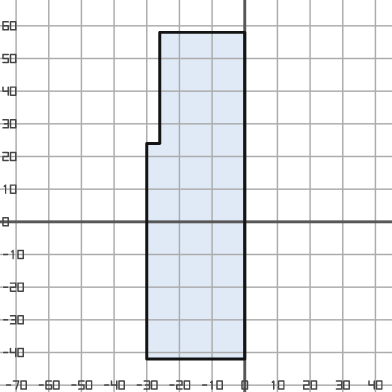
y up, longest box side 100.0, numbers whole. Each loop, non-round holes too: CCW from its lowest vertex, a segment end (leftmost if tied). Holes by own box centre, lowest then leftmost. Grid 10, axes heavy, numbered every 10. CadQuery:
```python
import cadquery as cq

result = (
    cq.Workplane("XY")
    .moveTo(-30.0, -42.0)
    .lineTo(0.0, -42.0)
    .lineTo(0.0, 58.0)
    .lineTo(-26.0, 58.0)
    .lineTo(-26.0, 24.0)
    .lineTo(-30.0, 24.0)
    .close()
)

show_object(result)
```